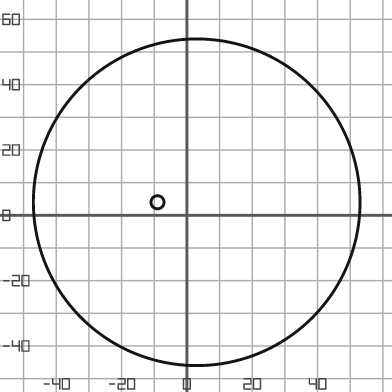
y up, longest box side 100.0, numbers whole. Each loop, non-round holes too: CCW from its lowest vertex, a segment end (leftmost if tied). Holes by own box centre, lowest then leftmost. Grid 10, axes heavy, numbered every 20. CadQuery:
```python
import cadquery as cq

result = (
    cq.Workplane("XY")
    .moveTo(3.0, 4.0)
    .circle(50.0)
    .moveTo(-9.0, 4.0)
    .circle(2.0)
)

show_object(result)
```